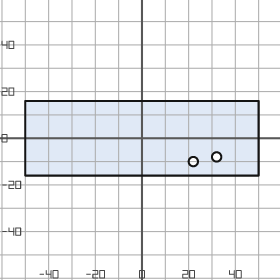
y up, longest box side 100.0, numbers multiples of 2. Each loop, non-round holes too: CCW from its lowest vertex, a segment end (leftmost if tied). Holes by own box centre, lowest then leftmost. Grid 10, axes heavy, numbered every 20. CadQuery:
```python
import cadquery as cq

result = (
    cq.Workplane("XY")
    .moveTo(-50.0, -16.0)
    .lineTo(50.0, -16.0)
    .lineTo(50.0, 16.0)
    .lineTo(-50.0, 16.0)
    .close()
    .moveTo(22.0, -10.0)
    .circle(2.0)
    .moveTo(32.0, -8.0)
    .circle(2.0)
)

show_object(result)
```